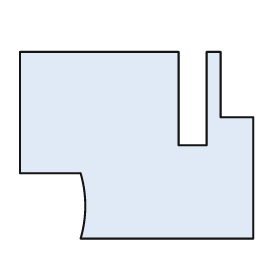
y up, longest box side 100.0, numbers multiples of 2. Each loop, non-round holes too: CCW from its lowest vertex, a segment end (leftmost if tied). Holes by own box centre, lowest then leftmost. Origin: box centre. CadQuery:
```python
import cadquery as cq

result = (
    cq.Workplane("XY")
    .moveTo(-24.0, -40.0)
    .lineTo(50.0, -40.0)
    .lineTo(50.0, 12.0)
    .lineTo(36.0, 12.0)
    .lineTo(36.0, 40.0)
    .lineTo(30.0, 40.0)
    .lineTo(30.0, 0.0)
    .lineTo(18.0, 0.0)
    .lineTo(18.0, 40.0)
    .lineTo(-50.0, 40.0)
    .lineTo(-50.0, -12.0)
    .lineTo(-24.0, -12.0)
    .threePointArc((-22.0, -26.0), (-24.0, -40.0))
    .close()
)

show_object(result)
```